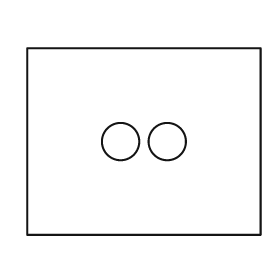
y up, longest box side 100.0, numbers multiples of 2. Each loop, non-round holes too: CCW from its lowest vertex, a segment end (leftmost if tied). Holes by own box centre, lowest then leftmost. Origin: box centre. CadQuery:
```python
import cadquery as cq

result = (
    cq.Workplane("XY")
    .moveTo(-50.0, -40.0)
    .lineTo(50.0, -40.0)
    .lineTo(50.0, 40.0)
    .lineTo(-50.0, 40.0)
    .close()
    .moveTo(-10.0, 0.0)
    .circle(8.0)
    .moveTo(10.0, 0.0)
    .circle(8.0)
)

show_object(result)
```